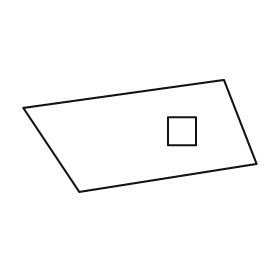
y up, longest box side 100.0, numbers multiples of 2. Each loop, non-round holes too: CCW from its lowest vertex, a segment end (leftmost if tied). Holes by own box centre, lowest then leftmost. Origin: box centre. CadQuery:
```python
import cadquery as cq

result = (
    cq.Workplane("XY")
    .moveTo(-26.0, -24.0)
    .lineTo(50.0, -12.0)
    .lineTo(36.0, 24.0)
    .lineTo(-50.0, 12.0)
    .close()
    .moveTo(12.0, -4.0)
    .lineTo(24.0, -4.0)
    .lineTo(24.0, 8.0)
    .lineTo(12.0, 8.0)
    .close()
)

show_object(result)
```